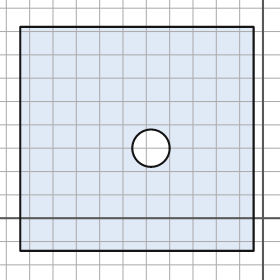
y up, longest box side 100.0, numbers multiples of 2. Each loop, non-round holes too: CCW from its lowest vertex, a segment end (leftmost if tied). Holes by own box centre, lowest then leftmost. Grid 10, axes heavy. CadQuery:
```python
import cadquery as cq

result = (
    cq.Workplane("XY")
    .moveTo(-104.0, -14.0)
    .lineTo(-4.0, -14.0)
    .lineTo(-4.0, 82.0)
    .lineTo(-104.0, 82.0)
    .close()
    .moveTo(-48.0, 30.0)
    .circle(8.0)
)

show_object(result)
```